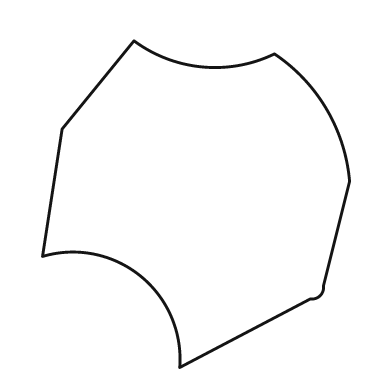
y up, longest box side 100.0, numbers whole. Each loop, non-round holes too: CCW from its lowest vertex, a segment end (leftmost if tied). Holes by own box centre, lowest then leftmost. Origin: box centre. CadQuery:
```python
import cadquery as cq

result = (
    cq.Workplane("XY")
    .moveTo(-5.0, -50.0)
    .lineTo(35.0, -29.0)
    .threePointArc((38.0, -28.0), (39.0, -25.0))
    .lineTo(47.0, 7.0)
    .threePointArc((40.0, 29.0), (24.0, 46.0))
    .threePointArc((2.0, 42.0), (-19.0, 50.0))
    .lineTo(-41.0, 23.0)
    .lineTo(-47.0, -16.0)
    .threePointArc((-17.0, -22.0), (-5.0, -50.0))
    .close()
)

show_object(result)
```